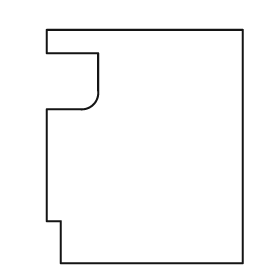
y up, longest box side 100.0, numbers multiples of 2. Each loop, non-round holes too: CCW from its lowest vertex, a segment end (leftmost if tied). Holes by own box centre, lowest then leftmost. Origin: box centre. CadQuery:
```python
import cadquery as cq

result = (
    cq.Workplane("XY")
    .moveTo(-36.0, -50.0)
    .lineTo(42.0, -50.0)
    .lineTo(42.0, 50.0)
    .lineTo(-42.0, 50.0)
    .lineTo(-42.0, 40.0)
    .lineTo(-20.0, 40.0)
    .lineTo(-20.0, 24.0)
    .threePointArc((-22.0, 18.0), (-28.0, 16.0))
    .lineTo(-42.0, 16.0)
    .lineTo(-42.0, -32.0)
    .lineTo(-36.0, -32.0)
    .close()
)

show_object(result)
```